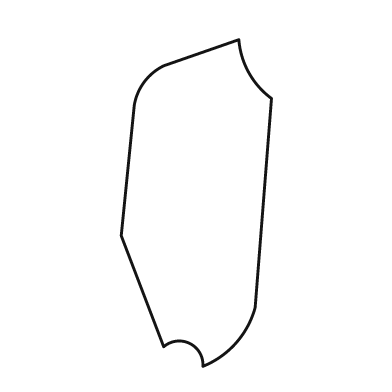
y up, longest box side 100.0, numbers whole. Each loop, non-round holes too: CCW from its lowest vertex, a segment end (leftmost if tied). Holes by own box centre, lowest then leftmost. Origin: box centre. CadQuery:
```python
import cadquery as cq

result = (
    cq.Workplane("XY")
    .moveTo(2.0, -50.0)
    .threePointArc((12.0, -43.0), (18.0, -32.0))
    .lineTo(23.0, 32.0)
    .threePointArc((16.0, 40.0), (13.0, 50.0))
    .lineTo(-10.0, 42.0)
    .threePointArc((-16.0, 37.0), (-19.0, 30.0))
    .lineTo(-23.0, -10.0)
    .lineTo(-10.0, -44.0)
    .threePointArc((-2.0, -43.0), (2.0, -50.0))
    .close()
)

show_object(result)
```